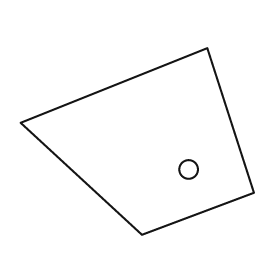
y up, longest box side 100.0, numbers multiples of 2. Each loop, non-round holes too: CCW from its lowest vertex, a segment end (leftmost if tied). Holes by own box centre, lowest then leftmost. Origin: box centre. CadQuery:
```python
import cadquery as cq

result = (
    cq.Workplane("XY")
    .moveTo(2.0, -40.0)
    .lineTo(50.0, -22.0)
    .lineTo(30.0, 40.0)
    .lineTo(-50.0, 8.0)
    .close()
    .moveTo(22.0, -12.0)
    .circle(4.0)
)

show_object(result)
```